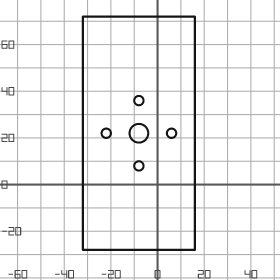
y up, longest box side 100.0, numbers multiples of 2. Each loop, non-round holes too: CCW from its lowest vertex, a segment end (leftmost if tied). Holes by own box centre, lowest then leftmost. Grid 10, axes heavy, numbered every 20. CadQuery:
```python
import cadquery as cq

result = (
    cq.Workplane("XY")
    .moveTo(-32.0, -28.0)
    .lineTo(16.0, -28.0)
    .lineTo(16.0, 72.0)
    .lineTo(-32.0, 72.0)
    .close()
    .moveTo(-8.0, 8.0)
    .circle(2.0)
    .moveTo(-22.0, 22.0)
    .circle(2.0)
    .moveTo(-8.0, 22.0)
    .circle(4.0)
    .moveTo(6.0, 22.0)
    .circle(2.0)
    .moveTo(-8.0, 36.0)
    .circle(2.0)
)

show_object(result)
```